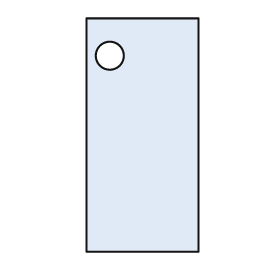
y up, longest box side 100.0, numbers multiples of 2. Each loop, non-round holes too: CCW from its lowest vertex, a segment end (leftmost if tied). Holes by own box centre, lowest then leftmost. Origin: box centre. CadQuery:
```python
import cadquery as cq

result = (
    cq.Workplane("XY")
    .moveTo(-24.0, -50.0)
    .lineTo(24.0, -50.0)
    .lineTo(24.0, 50.0)
    .lineTo(-24.0, 50.0)
    .close()
    .moveTo(-14.0, 34.0)
    .circle(6.0)
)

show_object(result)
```